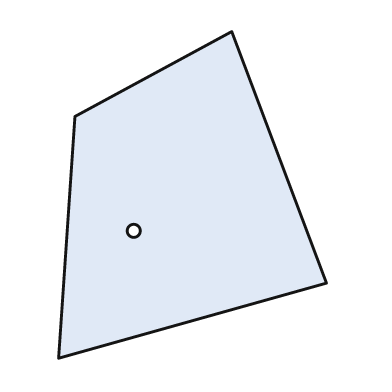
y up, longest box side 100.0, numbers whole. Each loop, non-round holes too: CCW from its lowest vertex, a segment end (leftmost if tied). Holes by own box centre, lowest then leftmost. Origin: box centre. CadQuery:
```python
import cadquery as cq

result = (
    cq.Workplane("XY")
    .moveTo(-41.0, -50.0)
    .lineTo(41.0, -27.0)
    .lineTo(12.0, 50.0)
    .lineTo(-36.0, 24.0)
    .close()
    .moveTo(-18.0, -11.0)
    .circle(2.0)
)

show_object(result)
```